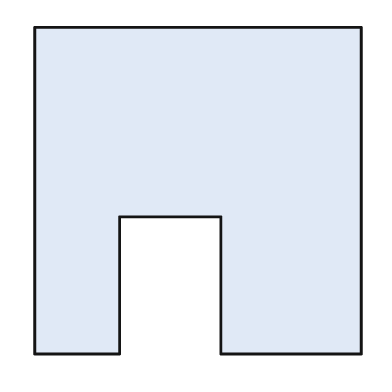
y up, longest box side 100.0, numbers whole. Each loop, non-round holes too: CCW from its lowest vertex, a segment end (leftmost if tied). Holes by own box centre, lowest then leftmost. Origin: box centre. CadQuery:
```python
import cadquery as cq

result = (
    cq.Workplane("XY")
    .moveTo(-50.0, -50.0)
    .lineTo(-24.0, -50.0)
    .lineTo(-24.0, -8.0)
    .lineTo(7.0, -8.0)
    .lineTo(7.0, -50.0)
    .lineTo(50.0, -50.0)
    .lineTo(50.0, 50.0)
    .lineTo(-50.0, 50.0)
    .close()
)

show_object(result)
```